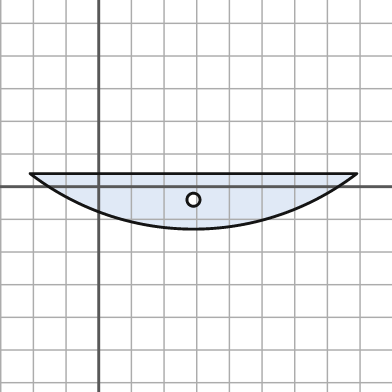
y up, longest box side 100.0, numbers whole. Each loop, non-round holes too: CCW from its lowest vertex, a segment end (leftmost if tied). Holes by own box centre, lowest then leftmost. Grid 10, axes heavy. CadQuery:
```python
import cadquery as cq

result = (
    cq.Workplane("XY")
    .moveTo(-21.0, 4.0)
    .threePointArc((29.0, -13.0), (79.0, 4.0))
    .close()
    .moveTo(29.0, -4.0)
    .circle(2.0)
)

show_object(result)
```